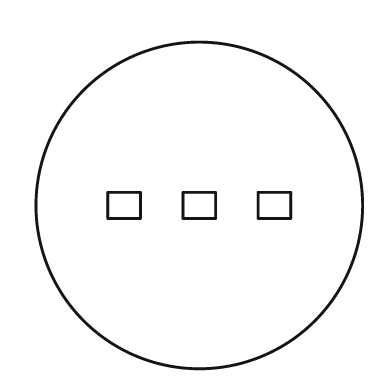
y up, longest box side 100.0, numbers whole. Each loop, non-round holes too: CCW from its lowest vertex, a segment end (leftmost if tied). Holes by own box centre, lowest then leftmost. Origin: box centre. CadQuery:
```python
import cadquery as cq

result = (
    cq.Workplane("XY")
    .moveTo(0.0, 0.0)
    .circle(50.0)
    .moveTo(-28.0, -4.0)
    .lineTo(-18.0, -4.0)
    .lineTo(-18.0, 4.0)
    .lineTo(-28.0, 4.0)
    .close()
    .moveTo(-5.0, -4.0)
    .lineTo(5.0, -4.0)
    .lineTo(5.0, 4.0)
    .lineTo(-5.0, 4.0)
    .close()
    .moveTo(18.0, -4.0)
    .lineTo(28.0, -4.0)
    .lineTo(28.0, 4.0)
    .lineTo(18.0, 4.0)
    .close()
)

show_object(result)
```